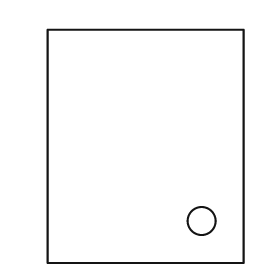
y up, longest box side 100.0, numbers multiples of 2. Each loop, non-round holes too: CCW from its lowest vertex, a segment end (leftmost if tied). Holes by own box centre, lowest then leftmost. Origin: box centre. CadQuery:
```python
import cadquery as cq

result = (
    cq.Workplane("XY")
    .moveTo(-42.0, -50.0)
    .lineTo(42.0, -50.0)
    .lineTo(42.0, 50.0)
    .lineTo(-42.0, 50.0)
    .close()
    .moveTo(24.0, -32.0)
    .circle(6.0)
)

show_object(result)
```